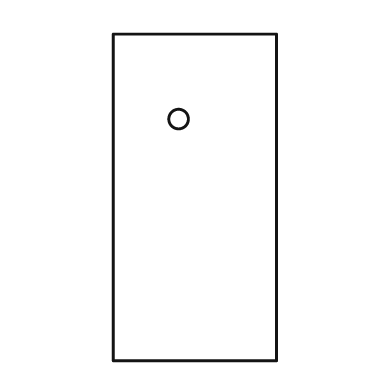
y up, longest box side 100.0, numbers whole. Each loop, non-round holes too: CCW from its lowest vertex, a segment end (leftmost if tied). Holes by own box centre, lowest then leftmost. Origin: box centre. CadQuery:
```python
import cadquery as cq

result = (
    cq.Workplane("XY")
    .moveTo(-25.0, -50.0)
    .lineTo(25.0, -50.0)
    .lineTo(25.0, 50.0)
    .lineTo(-25.0, 50.0)
    .close()
    .moveTo(-5.0, 24.0)
    .circle(3.0)
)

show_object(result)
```